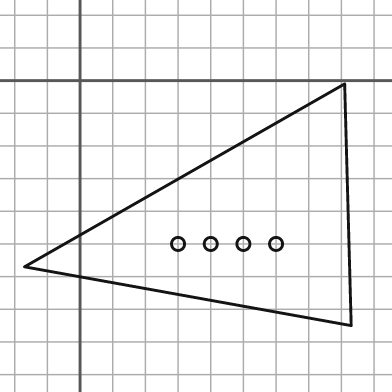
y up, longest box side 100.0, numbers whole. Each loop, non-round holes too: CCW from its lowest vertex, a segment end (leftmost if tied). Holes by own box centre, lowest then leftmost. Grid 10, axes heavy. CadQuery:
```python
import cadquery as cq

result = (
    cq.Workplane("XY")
    .moveTo(83.0, -75.0)
    .lineTo(81.0, -1.0)
    .lineTo(-17.0, -57.0)
    .close()
    .moveTo(30.0, -50.0)
    .circle(2.0)
    .moveTo(40.0, -50.0)
    .circle(2.0)
    .moveTo(50.0, -50.0)
    .circle(2.0)
    .moveTo(60.0, -50.0)
    .circle(2.0)
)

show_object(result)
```